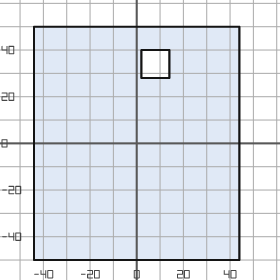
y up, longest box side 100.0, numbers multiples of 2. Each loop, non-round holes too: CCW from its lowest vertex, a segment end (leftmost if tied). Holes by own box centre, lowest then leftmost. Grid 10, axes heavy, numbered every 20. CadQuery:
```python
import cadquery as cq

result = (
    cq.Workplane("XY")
    .moveTo(-44.0, -50.0)
    .lineTo(44.0, -50.0)
    .lineTo(44.0, 50.0)
    .lineTo(-44.0, 50.0)
    .close()
    .moveTo(2.0, 28.0)
    .lineTo(14.0, 28.0)
    .lineTo(14.0, 40.0)
    .lineTo(2.0, 40.0)
    .close()
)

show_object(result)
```